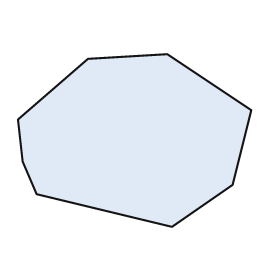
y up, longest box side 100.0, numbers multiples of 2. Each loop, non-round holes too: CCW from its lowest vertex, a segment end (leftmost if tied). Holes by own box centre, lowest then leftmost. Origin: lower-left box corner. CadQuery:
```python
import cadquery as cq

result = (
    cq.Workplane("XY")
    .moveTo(66.0, 0.0)
    .lineTo(92.0, 18.0)
    .lineTo(100.0, 50.0)
    .lineTo(64.0, 74.0)
    .lineTo(30.0, 72.0)
    .lineTo(0.0, 46.0)
    .lineTo(2.0, 28.0)
    .lineTo(8.0, 14.0)
    .close()
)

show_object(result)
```